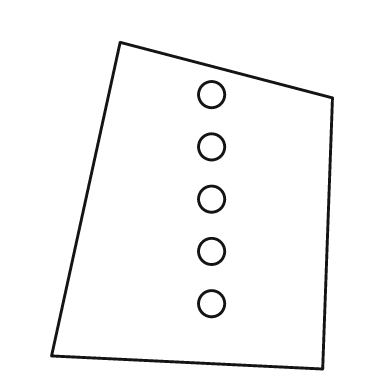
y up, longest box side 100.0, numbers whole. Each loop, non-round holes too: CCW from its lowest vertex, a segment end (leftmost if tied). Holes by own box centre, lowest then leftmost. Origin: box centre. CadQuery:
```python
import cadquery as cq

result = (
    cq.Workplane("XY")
    .moveTo(40.0, -50.0)
    .lineTo(43.0, 33.0)
    .lineTo(-22.0, 50.0)
    .lineTo(-43.0, -46.0)
    .close()
    .moveTo(6.0, -30.0)
    .circle(4.0)
    .moveTo(6.0, -14.0)
    .circle(4.0)
    .moveTo(6.0, 2.0)
    .circle(4.0)
    .moveTo(6.0, 18.0)
    .circle(4.0)
    .moveTo(6.0, 34.0)
    .circle(4.0)
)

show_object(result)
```